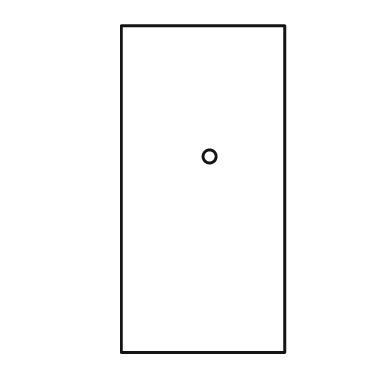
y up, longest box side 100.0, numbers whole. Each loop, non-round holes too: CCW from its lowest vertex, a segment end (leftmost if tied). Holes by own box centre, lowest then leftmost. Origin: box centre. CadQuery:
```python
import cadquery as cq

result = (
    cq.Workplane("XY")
    .moveTo(-25.0, -50.0)
    .lineTo(25.0, -50.0)
    .lineTo(25.0, 50.0)
    .lineTo(-25.0, 50.0)
    .close()
    .moveTo(2.0, 10.0)
    .circle(2.0)
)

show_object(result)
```